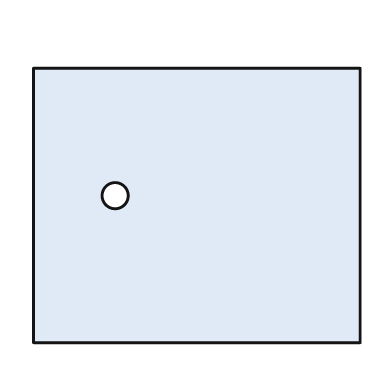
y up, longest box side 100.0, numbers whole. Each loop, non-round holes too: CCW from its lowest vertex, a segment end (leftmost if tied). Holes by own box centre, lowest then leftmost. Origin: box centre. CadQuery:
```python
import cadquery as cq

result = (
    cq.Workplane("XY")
    .moveTo(-50.0, -42.0)
    .lineTo(50.0, -42.0)
    .lineTo(50.0, 42.0)
    .lineTo(-50.0, 42.0)
    .close()
    .moveTo(-25.0, 3.0)
    .circle(4.0)
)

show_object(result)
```